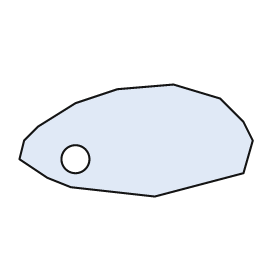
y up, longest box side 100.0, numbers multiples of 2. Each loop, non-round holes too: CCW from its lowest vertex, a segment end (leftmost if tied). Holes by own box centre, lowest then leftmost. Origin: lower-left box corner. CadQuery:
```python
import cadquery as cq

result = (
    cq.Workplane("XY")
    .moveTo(58.0, 0.0)
    .lineTo(96.0, 10.0)
    .lineTo(100.0, 24.0)
    .lineTo(96.0, 32.0)
    .lineTo(86.0, 42.0)
    .lineTo(66.0, 48.0)
    .lineTo(42.0, 46.0)
    .lineTo(24.0, 40.0)
    .lineTo(8.0, 30.0)
    .lineTo(2.0, 24.0)
    .lineTo(0.0, 16.0)
    .lineTo(12.0, 8.0)
    .lineTo(22.0, 4.0)
    .close()
    .moveTo(24.0, 16.0)
    .circle(6.0)
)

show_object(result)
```